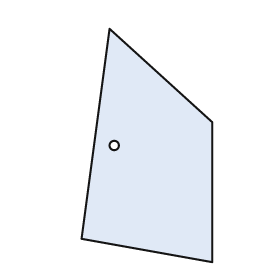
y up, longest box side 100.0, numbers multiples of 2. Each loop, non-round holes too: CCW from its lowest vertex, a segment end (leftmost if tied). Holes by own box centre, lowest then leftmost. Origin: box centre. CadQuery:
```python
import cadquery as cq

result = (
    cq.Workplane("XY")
    .moveTo(28.0, -50.0)
    .lineTo(28.0, 10.0)
    .lineTo(-16.0, 50.0)
    .lineTo(-28.0, -40.0)
    .close()
    .moveTo(-14.0, 0.0)
    .circle(2.0)
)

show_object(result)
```